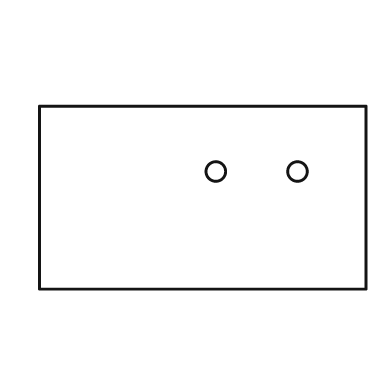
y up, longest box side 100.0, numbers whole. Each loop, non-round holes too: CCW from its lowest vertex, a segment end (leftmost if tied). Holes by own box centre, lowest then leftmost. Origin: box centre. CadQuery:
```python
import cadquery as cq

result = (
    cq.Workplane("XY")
    .moveTo(-50.0, -28.0)
    .lineTo(50.0, -28.0)
    .lineTo(50.0, 28.0)
    .lineTo(-50.0, 28.0)
    .close()
    .moveTo(4.0, 8.0)
    .circle(3.0)
    .moveTo(29.0, 8.0)
    .circle(3.0)
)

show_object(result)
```